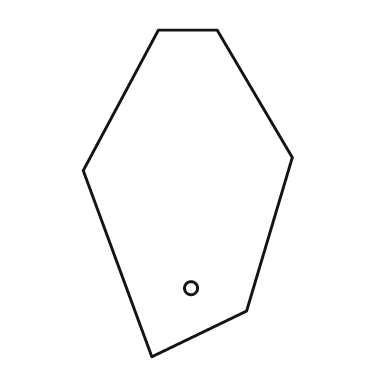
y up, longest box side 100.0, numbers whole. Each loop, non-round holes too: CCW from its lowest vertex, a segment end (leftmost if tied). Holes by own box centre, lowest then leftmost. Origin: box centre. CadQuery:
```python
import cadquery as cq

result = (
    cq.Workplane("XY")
    .moveTo(-11.0, -50.0)
    .lineTo(18.0, -36.0)
    .lineTo(32.0, 11.0)
    .lineTo(9.0, 50.0)
    .lineTo(-9.0, 50.0)
    .lineTo(-32.0, 7.0)
    .close()
    .moveTo(1.0, -29.0)
    .circle(2.0)
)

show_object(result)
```